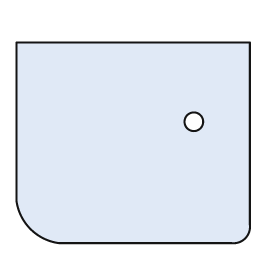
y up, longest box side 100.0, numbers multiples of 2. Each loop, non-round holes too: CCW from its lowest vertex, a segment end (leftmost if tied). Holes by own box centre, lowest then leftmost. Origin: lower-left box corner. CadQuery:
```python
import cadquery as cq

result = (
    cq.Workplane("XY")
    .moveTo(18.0, 0.0)
    .lineTo(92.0, 0.0)
    .threePointArc((98.0, 2.0), (100.0, 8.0))
    .lineTo(100.0, 86.0)
    .lineTo(0.0, 86.0)
    .lineTo(0.0, 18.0)
    .threePointArc((6.0, 6.0), (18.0, 0.0))
    .close()
    .moveTo(76.0, 52.0)
    .circle(4.0)
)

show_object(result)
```